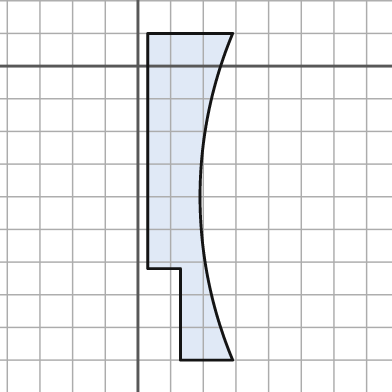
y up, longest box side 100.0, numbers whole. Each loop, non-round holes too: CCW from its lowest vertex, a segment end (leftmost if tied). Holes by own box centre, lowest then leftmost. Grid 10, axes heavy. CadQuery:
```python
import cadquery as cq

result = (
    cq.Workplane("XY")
    .moveTo(13.0, -90.0)
    .lineTo(29.0, -90.0)
    .threePointArc((19.0, -40.0), (29.0, 10.0))
    .lineTo(3.0, 10.0)
    .lineTo(3.0, -62.0)
    .lineTo(13.0, -62.0)
    .close()
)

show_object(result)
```